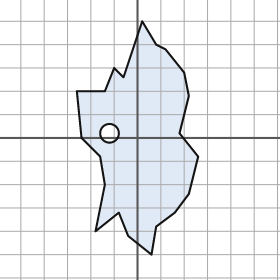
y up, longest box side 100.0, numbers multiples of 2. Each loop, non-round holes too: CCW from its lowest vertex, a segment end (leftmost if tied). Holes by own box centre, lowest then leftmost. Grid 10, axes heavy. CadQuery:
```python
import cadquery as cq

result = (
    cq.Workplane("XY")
    .moveTo(6.0, -50.0)
    .lineTo(8.0, -38.0)
    .lineTo(16.0, -32.0)
    .lineTo(22.0, -24.0)
    .lineTo(26.0, -8.0)
    .lineTo(18.0, 2.0)
    .lineTo(22.0, 18.0)
    .lineTo(20.0, 28.0)
    .lineTo(12.0, 38.0)
    .lineTo(8.0, 40.0)
    .lineTo(2.0, 50.0)
    .lineTo(-6.0, 26.0)
    .lineTo(-10.0, 30.0)
    .lineTo(-14.0, 20.0)
    .lineTo(-26.0, 20.0)
    .lineTo(-24.0, 0.0)
    .lineTo(-16.0, -8.0)
    .lineTo(-14.0, -20.0)
    .lineTo(-18.0, -40.0)
    .lineTo(-8.0, -32.0)
    .lineTo(-4.0, -42.0)
    .close()
    .moveTo(-12.0, 2.0)
    .circle(4.0)
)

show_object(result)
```